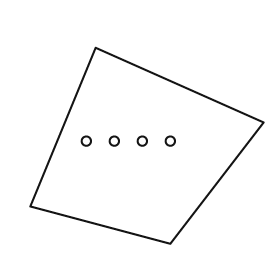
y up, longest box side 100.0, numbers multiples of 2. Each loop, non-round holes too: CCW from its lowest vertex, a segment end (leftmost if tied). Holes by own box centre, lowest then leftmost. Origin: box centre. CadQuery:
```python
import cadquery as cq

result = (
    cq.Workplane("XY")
    .moveTo(10.0, -42.0)
    .lineTo(50.0, 10.0)
    .lineTo(-22.0, 42.0)
    .lineTo(-50.0, -26.0)
    .close()
    .moveTo(-26.0, 2.0)
    .circle(2.0)
    .moveTo(-14.0, 2.0)
    .circle(2.0)
    .moveTo(-2.0, 2.0)
    .circle(2.0)
    .moveTo(10.0, 2.0)
    .circle(2.0)
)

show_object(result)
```